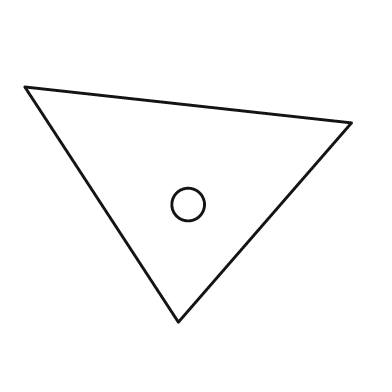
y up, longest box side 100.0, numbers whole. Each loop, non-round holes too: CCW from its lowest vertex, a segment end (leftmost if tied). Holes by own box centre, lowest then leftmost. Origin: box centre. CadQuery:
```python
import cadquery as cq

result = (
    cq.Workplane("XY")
    .moveTo(-3.0, -36.0)
    .lineTo(50.0, 25.0)
    .lineTo(-50.0, 36.0)
    .close()
    .moveTo(0.0, 0.0)
    .circle(5.0)
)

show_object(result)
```